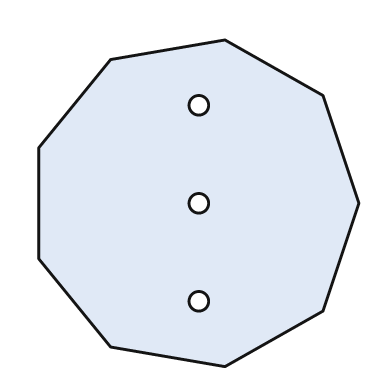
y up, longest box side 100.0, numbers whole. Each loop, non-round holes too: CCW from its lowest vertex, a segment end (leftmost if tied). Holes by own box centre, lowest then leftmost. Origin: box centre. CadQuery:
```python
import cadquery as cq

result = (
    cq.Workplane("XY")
    .moveTo(8.0, -50.0)
    .lineTo(38.0, -33.0)
    .lineTo(49.0, 0.0)
    .lineTo(38.0, 33.0)
    .lineTo(8.0, 50.0)
    .lineTo(-27.0, 44.0)
    .lineTo(-49.0, 17.0)
    .lineTo(-49.0, -17.0)
    .lineTo(-27.0, -44.0)
    .close()
    .moveTo(0.0, -30.0)
    .circle(3.0)
    .moveTo(0.0, 0.0)
    .circle(3.0)
    .moveTo(0.0, 30.0)
    .circle(3.0)
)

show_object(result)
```